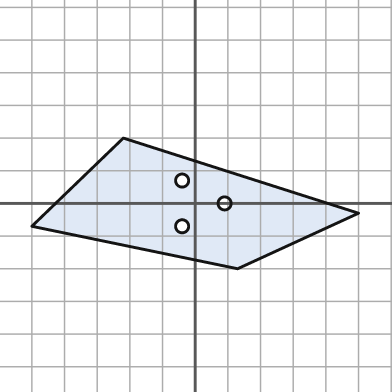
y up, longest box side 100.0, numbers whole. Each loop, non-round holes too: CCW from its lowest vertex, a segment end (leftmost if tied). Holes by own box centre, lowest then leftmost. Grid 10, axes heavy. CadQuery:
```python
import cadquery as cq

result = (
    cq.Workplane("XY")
    .moveTo(13.0, -20.0)
    .lineTo(50.0, -3.0)
    .lineTo(-22.0, 20.0)
    .lineTo(-50.0, -7.0)
    .close()
    .moveTo(-4.0, -7.0)
    .circle(2.0)
    .moveTo(9.0, 0.0)
    .circle(2.0)
    .moveTo(-4.0, 7.0)
    .circle(2.0)
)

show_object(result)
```